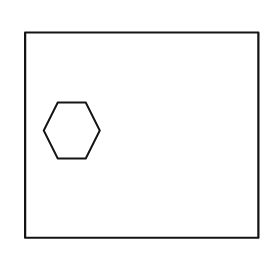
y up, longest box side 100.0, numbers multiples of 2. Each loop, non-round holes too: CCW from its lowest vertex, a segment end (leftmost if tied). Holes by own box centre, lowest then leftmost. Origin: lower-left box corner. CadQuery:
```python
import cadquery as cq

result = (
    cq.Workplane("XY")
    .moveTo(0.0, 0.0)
    .lineTo(100.0, 0.0)
    .lineTo(100.0, 88.0)
    .lineTo(0.0, 88.0)
    .close()
    .moveTo(14.0, 34.0)
    .lineTo(26.0, 34.0)
    .lineTo(32.0, 46.0)
    .lineTo(26.0, 58.0)
    .lineTo(14.0, 58.0)
    .lineTo(8.0, 46.0)
    .close()
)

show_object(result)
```